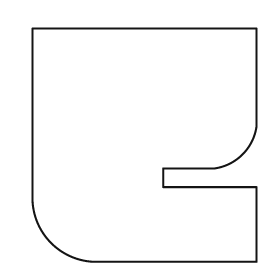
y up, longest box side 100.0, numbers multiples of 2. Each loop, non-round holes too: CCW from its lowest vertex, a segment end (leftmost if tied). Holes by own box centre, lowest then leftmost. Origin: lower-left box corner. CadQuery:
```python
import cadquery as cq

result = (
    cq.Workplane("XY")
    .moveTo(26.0, 0.0)
    .lineTo(96.0, 0.0)
    .lineTo(96.0, 32.0)
    .lineTo(56.0, 32.0)
    .lineTo(56.0, 40.0)
    .lineTo(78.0, 40.0)
    .threePointArc((90.0, 46.0), (96.0, 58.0))
    .lineTo(96.0, 100.0)
    .lineTo(0.0, 100.0)
    .lineTo(0.0, 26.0)
    .threePointArc((8.0, 8.0), (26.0, 0.0))
    .close()
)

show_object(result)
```